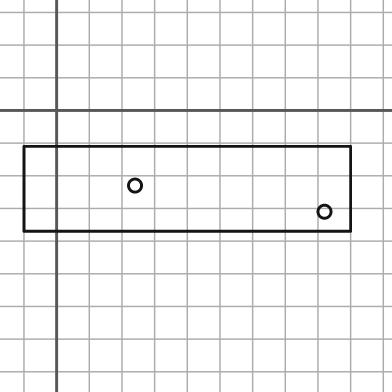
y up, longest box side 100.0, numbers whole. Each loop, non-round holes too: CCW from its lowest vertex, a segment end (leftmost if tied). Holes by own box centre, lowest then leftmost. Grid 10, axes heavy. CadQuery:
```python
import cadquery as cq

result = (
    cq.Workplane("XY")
    .moveTo(-10.0, -37.0)
    .lineTo(90.0, -37.0)
    .lineTo(90.0, -11.0)
    .lineTo(-10.0, -11.0)
    .close()
    .moveTo(82.0, -31.0)
    .circle(2.0)
    .moveTo(24.0, -23.0)
    .circle(2.0)
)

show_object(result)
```